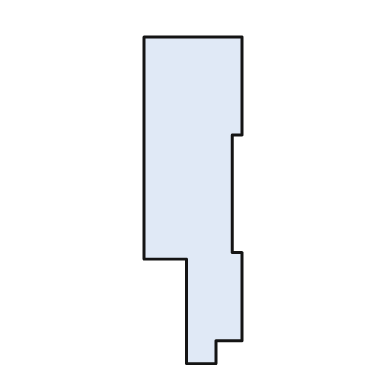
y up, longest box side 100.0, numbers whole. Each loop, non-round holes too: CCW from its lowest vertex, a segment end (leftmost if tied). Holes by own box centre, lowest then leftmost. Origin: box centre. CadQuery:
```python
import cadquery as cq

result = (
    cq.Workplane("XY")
    .moveTo(-2.0, -50.0)
    .lineTo(7.0, -50.0)
    .lineTo(7.0, -43.0)
    .lineTo(15.0, -43.0)
    .lineTo(15.0, -16.0)
    .lineTo(12.0, -16.0)
    .lineTo(12.0, 20.0)
    .lineTo(15.0, 20.0)
    .lineTo(15.0, 50.0)
    .lineTo(-15.0, 50.0)
    .lineTo(-15.0, -18.0)
    .lineTo(-2.0, -18.0)
    .close()
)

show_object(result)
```